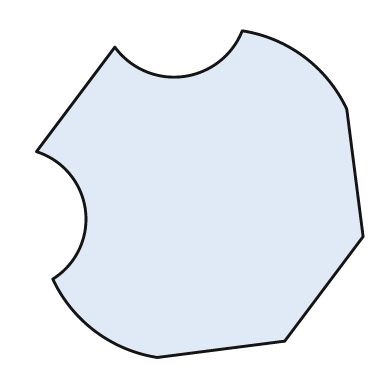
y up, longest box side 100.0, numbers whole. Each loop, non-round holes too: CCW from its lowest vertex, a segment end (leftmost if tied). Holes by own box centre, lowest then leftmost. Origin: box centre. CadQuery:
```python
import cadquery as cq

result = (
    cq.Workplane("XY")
    .moveTo(-13.0, -50.0)
    .lineTo(26.0, -45.0)
    .lineTo(50.0, -13.0)
    .lineTo(45.0, 26.0)
    .threePointArc((32.0, 42.0), (13.0, 50.0))
    .threePointArc((-5.0, 36.0), (-26.0, 45.0))
    .lineTo(-50.0, 13.0)
    .threePointArc((-35.0, -5.0), (-45.0, -26.0))
    .threePointArc((-32.0, -42.0), (-13.0, -50.0))
    .close()
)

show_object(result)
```